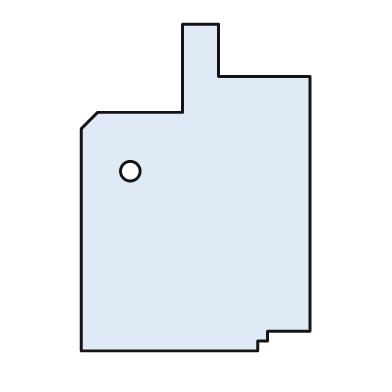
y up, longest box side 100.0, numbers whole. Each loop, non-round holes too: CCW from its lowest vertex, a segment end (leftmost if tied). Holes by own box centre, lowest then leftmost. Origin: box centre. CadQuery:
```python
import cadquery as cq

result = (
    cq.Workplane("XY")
    .moveTo(-35.0, -50.0)
    .lineTo(19.0, -50.0)
    .lineTo(19.0, -47.0)
    .lineTo(22.0, -47.0)
    .lineTo(22.0, -44.0)
    .lineTo(35.0, -44.0)
    .lineTo(35.0, 34.0)
    .lineTo(7.0, 34.0)
    .lineTo(7.0, 50.0)
    .lineTo(-4.0, 50.0)
    .lineTo(-4.0, 23.0)
    .lineTo(-30.0, 23.0)
    .lineTo(-35.0, 18.0)
    .close()
    .moveTo(-20.0, 5.0)
    .circle(3.0)
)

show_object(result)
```